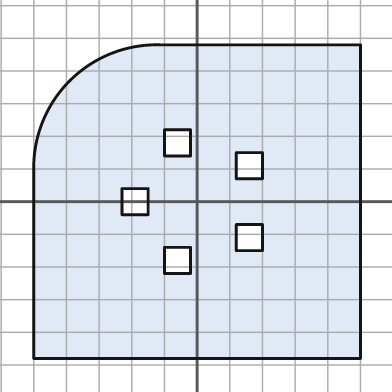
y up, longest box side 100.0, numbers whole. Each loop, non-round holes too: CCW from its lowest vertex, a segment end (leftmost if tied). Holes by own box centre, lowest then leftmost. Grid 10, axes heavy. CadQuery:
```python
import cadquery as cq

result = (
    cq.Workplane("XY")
    .moveTo(-50.0, -48.0)
    .lineTo(50.0, -48.0)
    .lineTo(50.0, 48.0)
    .lineTo(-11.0, 48.0)
    .threePointArc((-39.0, 37.0), (-50.0, 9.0))
    .close()
    .moveTo(-10.0, -22.0)
    .lineTo(-2.0, -22.0)
    .lineTo(-2.0, -14.0)
    .lineTo(-10.0, -14.0)
    .close()
    .moveTo(12.0, -15.0)
    .lineTo(20.0, -15.0)
    .lineTo(20.0, -7.0)
    .lineTo(12.0, -7.0)
    .close()
    .moveTo(-23.0, -4.0)
    .lineTo(-15.0, -4.0)
    .lineTo(-15.0, 4.0)
    .lineTo(-23.0, 4.0)
    .close()
    .moveTo(12.0, 7.0)
    .lineTo(20.0, 7.0)
    .lineTo(20.0, 15.0)
    .lineTo(12.0, 15.0)
    .close()
    .moveTo(-10.0, 14.0)
    .lineTo(-2.0, 14.0)
    .lineTo(-2.0, 22.0)
    .lineTo(-10.0, 22.0)
    .close()
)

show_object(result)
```